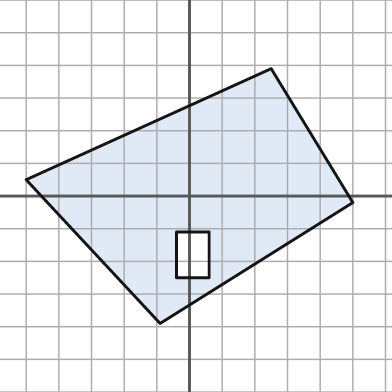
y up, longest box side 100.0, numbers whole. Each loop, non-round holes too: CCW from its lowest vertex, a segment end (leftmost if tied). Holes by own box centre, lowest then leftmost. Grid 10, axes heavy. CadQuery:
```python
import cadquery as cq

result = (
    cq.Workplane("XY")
    .moveTo(-9.0, -39.0)
    .lineTo(50.0, -2.0)
    .lineTo(25.0, 39.0)
    .lineTo(-50.0, 5.0)
    .close()
    .moveTo(-4.0, -25.0)
    .lineTo(6.0, -25.0)
    .lineTo(6.0, -11.0)
    .lineTo(-4.0, -11.0)
    .close()
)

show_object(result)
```